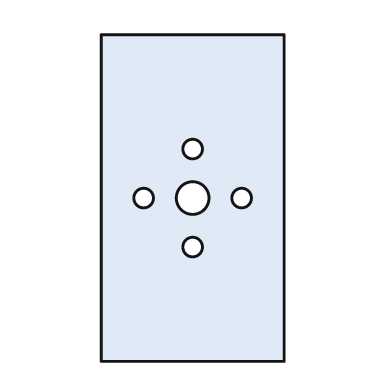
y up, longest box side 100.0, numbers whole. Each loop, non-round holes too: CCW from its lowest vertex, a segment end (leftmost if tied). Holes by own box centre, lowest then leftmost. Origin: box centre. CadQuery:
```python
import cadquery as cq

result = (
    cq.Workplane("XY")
    .moveTo(-28.0, -50.0)
    .lineTo(28.0, -50.0)
    .lineTo(28.0, 50.0)
    .lineTo(-28.0, 50.0)
    .close()
    .moveTo(0.0, -15.0)
    .circle(3.0)
    .moveTo(-15.0, 0.0)
    .circle(3.0)
    .moveTo(0.0, 0.0)
    .circle(5.0)
    .moveTo(15.0, 0.0)
    .circle(3.0)
    .moveTo(0.0, 15.0)
    .circle(3.0)
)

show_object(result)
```